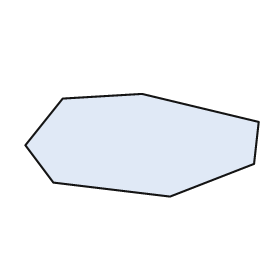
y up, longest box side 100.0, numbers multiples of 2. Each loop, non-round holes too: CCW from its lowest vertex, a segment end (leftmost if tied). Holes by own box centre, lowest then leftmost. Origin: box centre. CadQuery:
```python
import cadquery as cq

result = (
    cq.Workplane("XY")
    .moveTo(12.0, -22.0)
    .lineTo(48.0, -8.0)
    .lineTo(50.0, 10.0)
    .lineTo(0.0, 22.0)
    .lineTo(-34.0, 20.0)
    .lineTo(-50.0, 0.0)
    .lineTo(-38.0, -16.0)
    .close()
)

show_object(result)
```